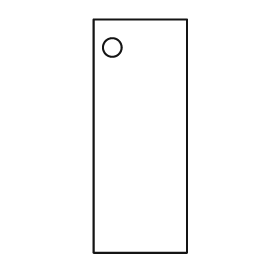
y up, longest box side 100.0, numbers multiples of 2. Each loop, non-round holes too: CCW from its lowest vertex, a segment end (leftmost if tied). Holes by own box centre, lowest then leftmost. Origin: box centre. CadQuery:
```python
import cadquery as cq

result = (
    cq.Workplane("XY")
    .moveTo(-20.0, -50.0)
    .lineTo(20.0, -50.0)
    .lineTo(20.0, 50.0)
    .lineTo(-20.0, 50.0)
    .close()
    .moveTo(-12.0, 38.0)
    .circle(4.0)
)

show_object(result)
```